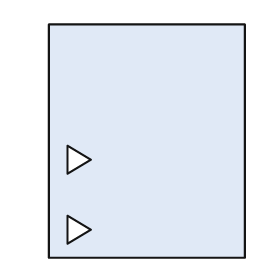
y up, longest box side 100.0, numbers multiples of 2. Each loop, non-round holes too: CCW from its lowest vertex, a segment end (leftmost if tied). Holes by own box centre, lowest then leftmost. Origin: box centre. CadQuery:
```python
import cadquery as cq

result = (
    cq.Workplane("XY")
    .moveTo(-42.0, -50.0)
    .lineTo(42.0, -50.0)
    .lineTo(42.0, 50.0)
    .lineTo(-42.0, 50.0)
    .close()
    .moveTo(-34.0, -44.0)
    .lineTo(-24.0, -38.0)
    .lineTo(-34.0, -32.0)
    .close()
    .moveTo(-34.0, -14.0)
    .lineTo(-24.0, -8.0)
    .lineTo(-34.0, -2.0)
    .close()
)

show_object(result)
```